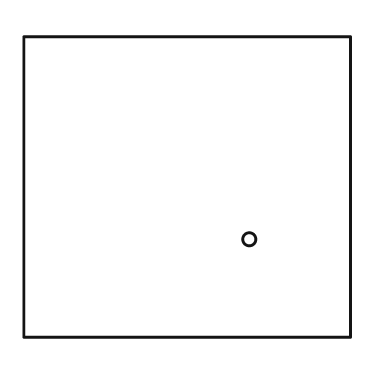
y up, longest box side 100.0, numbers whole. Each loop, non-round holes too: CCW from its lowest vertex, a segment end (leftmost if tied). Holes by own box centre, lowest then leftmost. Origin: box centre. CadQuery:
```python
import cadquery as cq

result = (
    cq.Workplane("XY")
    .moveTo(-50.0, -46.0)
    .lineTo(50.0, -46.0)
    .lineTo(50.0, 46.0)
    .lineTo(-50.0, 46.0)
    .close()
    .moveTo(19.0, -16.0)
    .circle(2.0)
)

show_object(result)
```